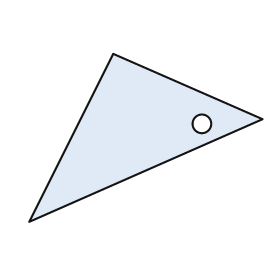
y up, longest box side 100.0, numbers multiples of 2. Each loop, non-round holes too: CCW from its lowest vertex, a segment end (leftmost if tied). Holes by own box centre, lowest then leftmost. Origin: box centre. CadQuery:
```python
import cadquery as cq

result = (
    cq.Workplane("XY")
    .moveTo(-50.0, -36.0)
    .lineTo(50.0, 8.0)
    .lineTo(-14.0, 36.0)
    .close()
    .moveTo(24.0, 6.0)
    .circle(4.0)
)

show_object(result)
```